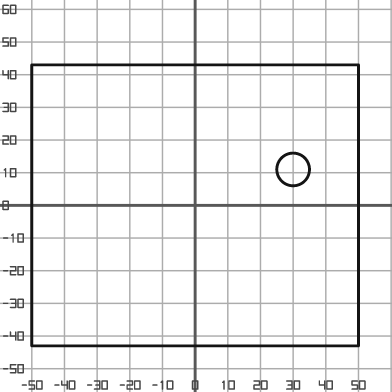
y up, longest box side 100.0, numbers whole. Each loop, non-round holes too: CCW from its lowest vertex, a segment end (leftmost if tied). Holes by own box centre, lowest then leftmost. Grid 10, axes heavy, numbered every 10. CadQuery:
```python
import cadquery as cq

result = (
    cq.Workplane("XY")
    .moveTo(-50.0, -43.0)
    .lineTo(50.0, -43.0)
    .lineTo(50.0, 43.0)
    .lineTo(-50.0, 43.0)
    .close()
    .moveTo(30.0, 11.0)
    .circle(5.0)
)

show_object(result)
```